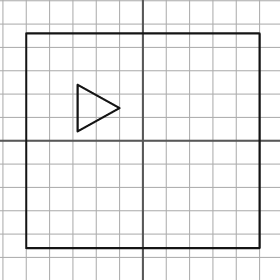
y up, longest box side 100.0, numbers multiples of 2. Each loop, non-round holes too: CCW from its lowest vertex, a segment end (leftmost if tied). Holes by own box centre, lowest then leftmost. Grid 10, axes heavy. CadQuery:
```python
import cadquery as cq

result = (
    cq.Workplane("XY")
    .moveTo(-50.0, -46.0)
    .lineTo(50.0, -46.0)
    .lineTo(50.0, 46.0)
    .lineTo(-50.0, 46.0)
    .close()
    .moveTo(-28.0, 4.0)
    .lineTo(-10.0, 14.0)
    .lineTo(-28.0, 24.0)
    .close()
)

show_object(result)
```